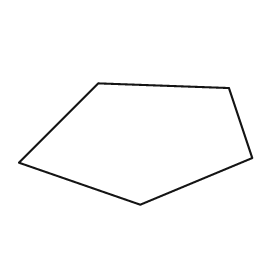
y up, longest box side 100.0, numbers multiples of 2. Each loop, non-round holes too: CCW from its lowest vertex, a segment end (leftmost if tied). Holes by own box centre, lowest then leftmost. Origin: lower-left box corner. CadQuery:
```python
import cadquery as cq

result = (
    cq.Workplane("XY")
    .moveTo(52.0, 0.0)
    .lineTo(100.0, 20.0)
    .lineTo(90.0, 50.0)
    .lineTo(34.0, 52.0)
    .lineTo(0.0, 18.0)
    .close()
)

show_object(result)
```